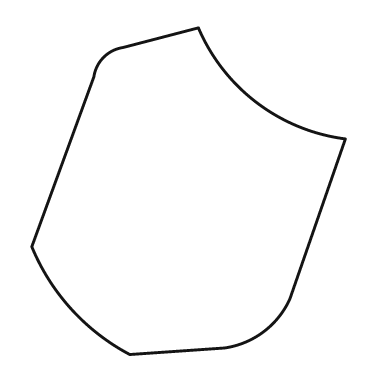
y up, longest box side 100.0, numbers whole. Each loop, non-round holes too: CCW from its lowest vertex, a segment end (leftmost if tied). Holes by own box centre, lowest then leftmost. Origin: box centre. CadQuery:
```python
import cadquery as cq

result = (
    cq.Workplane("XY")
    .moveTo(-18.0, -50.0)
    .lineTo(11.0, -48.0)
    .threePointArc((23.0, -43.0), (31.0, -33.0))
    .lineTo(48.0, 16.0)
    .threePointArc((21.0, 27.0), (3.0, 50.0))
    .lineTo(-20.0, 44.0)
    .threePointArc((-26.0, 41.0), (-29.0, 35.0))
    .lineTo(-48.0, -17.0)
    .threePointArc((-36.0, -36.0), (-18.0, -50.0))
    .close()
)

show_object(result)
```